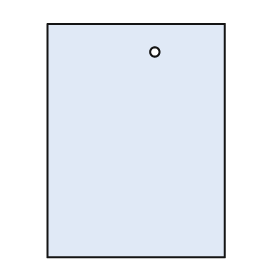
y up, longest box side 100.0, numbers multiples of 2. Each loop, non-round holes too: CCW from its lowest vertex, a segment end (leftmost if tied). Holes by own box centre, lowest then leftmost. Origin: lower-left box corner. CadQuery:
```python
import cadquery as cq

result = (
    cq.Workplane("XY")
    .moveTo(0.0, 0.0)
    .lineTo(76.0, 0.0)
    .lineTo(76.0, 100.0)
    .lineTo(0.0, 100.0)
    .close()
    .moveTo(46.0, 88.0)
    .circle(2.0)
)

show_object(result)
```